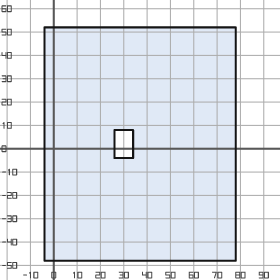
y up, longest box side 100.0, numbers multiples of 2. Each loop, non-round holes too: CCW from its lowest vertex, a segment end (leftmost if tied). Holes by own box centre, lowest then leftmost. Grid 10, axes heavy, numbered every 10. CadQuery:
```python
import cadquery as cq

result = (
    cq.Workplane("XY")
    .moveTo(-4.0, -48.0)
    .lineTo(78.0, -48.0)
    .lineTo(78.0, 52.0)
    .lineTo(-4.0, 52.0)
    .close()
    .moveTo(26.0, -4.0)
    .lineTo(34.0, -4.0)
    .lineTo(34.0, 8.0)
    .lineTo(26.0, 8.0)
    .close()
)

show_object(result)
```